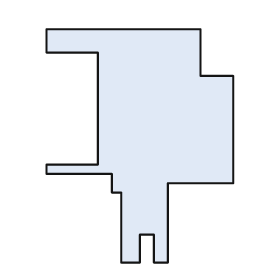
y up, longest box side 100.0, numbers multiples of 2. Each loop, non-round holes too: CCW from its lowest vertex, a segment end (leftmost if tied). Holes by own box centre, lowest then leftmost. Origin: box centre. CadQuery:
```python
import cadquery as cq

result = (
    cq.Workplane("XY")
    .moveTo(-8.0, -50.0)
    .lineTo(0.0, -50.0)
    .lineTo(0.0, -38.0)
    .lineTo(6.0, -38.0)
    .lineTo(6.0, -50.0)
    .lineTo(12.0, -50.0)
    .lineTo(12.0, -16.0)
    .lineTo(40.0, -16.0)
    .lineTo(40.0, 30.0)
    .lineTo(26.0, 30.0)
    .lineTo(26.0, 50.0)
    .lineTo(-40.0, 50.0)
    .lineTo(-40.0, 40.0)
    .lineTo(-18.0, 40.0)
    .lineTo(-18.0, -8.0)
    .lineTo(-40.0, -8.0)
    .lineTo(-40.0, -12.0)
    .lineTo(-12.0, -12.0)
    .lineTo(-12.0, -20.0)
    .lineTo(-8.0, -20.0)
    .close()
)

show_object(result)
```